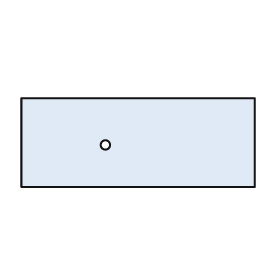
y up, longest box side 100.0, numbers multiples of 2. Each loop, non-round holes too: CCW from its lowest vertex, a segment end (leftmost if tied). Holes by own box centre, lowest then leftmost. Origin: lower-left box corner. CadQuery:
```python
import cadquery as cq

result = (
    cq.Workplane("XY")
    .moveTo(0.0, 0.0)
    .lineTo(100.0, 0.0)
    .lineTo(100.0, 38.0)
    .lineTo(0.0, 38.0)
    .close()
    .moveTo(36.0, 18.0)
    .circle(2.0)
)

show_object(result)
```